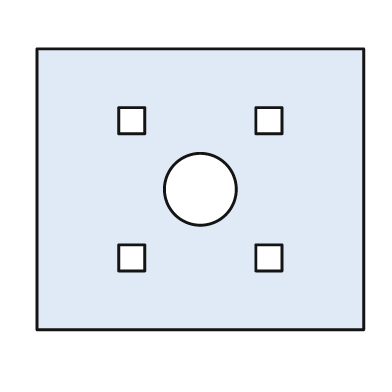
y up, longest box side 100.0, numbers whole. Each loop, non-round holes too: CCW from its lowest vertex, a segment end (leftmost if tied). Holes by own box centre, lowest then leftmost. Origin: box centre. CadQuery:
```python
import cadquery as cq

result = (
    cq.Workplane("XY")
    .moveTo(-50.0, -43.0)
    .lineTo(50.0, -43.0)
    .lineTo(50.0, 43.0)
    .lineTo(-50.0, 43.0)
    .close()
    .moveTo(-25.0, -25.0)
    .lineTo(-17.0, -25.0)
    .lineTo(-17.0, -17.0)
    .lineTo(-25.0, -17.0)
    .close()
    .moveTo(17.0, -25.0)
    .lineTo(25.0, -25.0)
    .lineTo(25.0, -17.0)
    .lineTo(17.0, -17.0)
    .close()
    .moveTo(0.0, 0.0)
    .circle(11.0)
    .moveTo(-25.0, 17.0)
    .lineTo(-17.0, 17.0)
    .lineTo(-17.0, 25.0)
    .lineTo(-25.0, 25.0)
    .close()
    .moveTo(17.0, 17.0)
    .lineTo(25.0, 17.0)
    .lineTo(25.0, 25.0)
    .lineTo(17.0, 25.0)
    .close()
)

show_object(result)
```